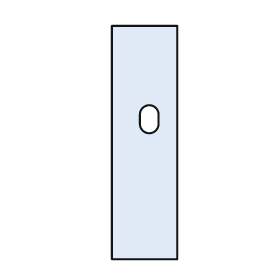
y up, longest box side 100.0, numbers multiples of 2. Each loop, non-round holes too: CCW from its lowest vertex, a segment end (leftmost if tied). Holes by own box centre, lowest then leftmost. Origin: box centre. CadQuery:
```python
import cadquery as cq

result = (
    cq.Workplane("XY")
    .moveTo(-14.0, -50.0)
    .lineTo(14.0, -50.0)
    .lineTo(14.0, 50.0)
    .lineTo(-14.0, 50.0)
    .close()
    .moveTo(-2.0, 8.0)
    .threePointArc((2.0, 4.0), (6.0, 8.0))
    .lineTo(6.0, 12.0)
    .threePointArc((2.0, 16.0), (-2.0, 12.0))
    .close()
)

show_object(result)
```